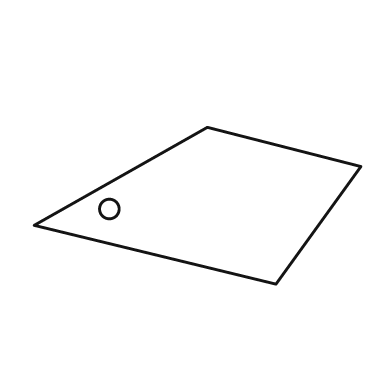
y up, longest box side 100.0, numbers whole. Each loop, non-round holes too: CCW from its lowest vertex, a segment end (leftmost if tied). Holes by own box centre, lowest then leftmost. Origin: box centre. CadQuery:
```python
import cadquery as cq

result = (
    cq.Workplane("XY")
    .moveTo(24.0, -24.0)
    .lineTo(50.0, 12.0)
    .lineTo(3.0, 24.0)
    .lineTo(-50.0, -6.0)
    .close()
    .moveTo(-27.0, -1.0)
    .circle(3.0)
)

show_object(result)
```